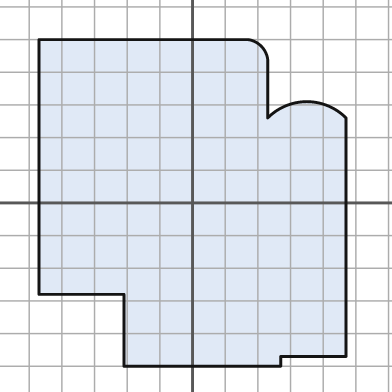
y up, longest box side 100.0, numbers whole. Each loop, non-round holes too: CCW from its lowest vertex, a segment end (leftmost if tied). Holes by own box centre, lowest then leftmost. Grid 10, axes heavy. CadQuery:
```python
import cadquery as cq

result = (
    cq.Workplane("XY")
    .moveTo(-21.0, -50.0)
    .lineTo(27.0, -50.0)
    .lineTo(27.0, -47.0)
    .lineTo(47.0, -47.0)
    .lineTo(47.0, 26.0)
    .threePointArc((35.0, 31.0), (23.0, 26.0))
    .lineTo(23.0, 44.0)
    .threePointArc((21.0, 48.0), (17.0, 50.0))
    .lineTo(-47.0, 50.0)
    .lineTo(-47.0, -28.0)
    .lineTo(-21.0, -28.0)
    .close()
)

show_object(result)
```